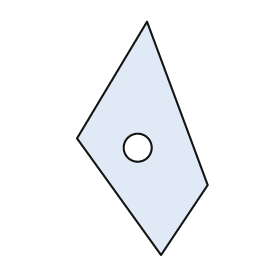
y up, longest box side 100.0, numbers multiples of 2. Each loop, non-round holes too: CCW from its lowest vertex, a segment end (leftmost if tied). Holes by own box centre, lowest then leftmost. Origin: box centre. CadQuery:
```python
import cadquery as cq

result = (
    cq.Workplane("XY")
    .moveTo(8.0, -50.0)
    .lineTo(28.0, -20.0)
    .lineTo(2.0, 50.0)
    .lineTo(-28.0, 0.0)
    .close()
    .moveTo(-2.0, -4.0)
    .circle(6.0)
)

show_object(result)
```